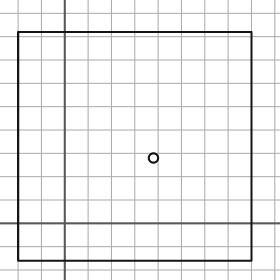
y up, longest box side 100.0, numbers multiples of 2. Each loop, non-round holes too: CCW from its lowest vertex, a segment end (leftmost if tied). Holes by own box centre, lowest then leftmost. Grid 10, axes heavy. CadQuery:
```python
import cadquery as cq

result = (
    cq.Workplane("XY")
    .moveTo(-20.0, -16.0)
    .lineTo(80.0, -16.0)
    .lineTo(80.0, 82.0)
    .lineTo(-20.0, 82.0)
    .close()
    .moveTo(38.0, 28.0)
    .circle(2.0)
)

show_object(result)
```